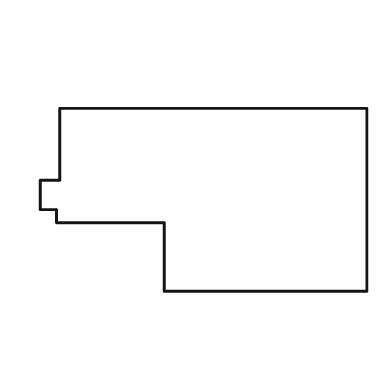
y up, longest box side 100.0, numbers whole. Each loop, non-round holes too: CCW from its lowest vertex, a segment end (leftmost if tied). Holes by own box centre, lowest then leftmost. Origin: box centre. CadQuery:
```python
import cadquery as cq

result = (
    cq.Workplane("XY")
    .moveTo(-12.0, -28.0)
    .lineTo(50.0, -28.0)
    .lineTo(50.0, 28.0)
    .lineTo(-44.0, 28.0)
    .lineTo(-44.0, 6.0)
    .lineTo(-50.0, 6.0)
    .lineTo(-50.0, -3.0)
    .lineTo(-45.0, -3.0)
    .lineTo(-45.0, -7.0)
    .lineTo(-12.0, -7.0)
    .close()
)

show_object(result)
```